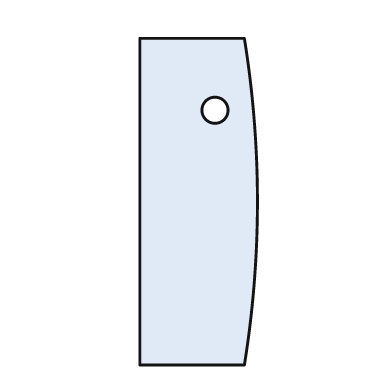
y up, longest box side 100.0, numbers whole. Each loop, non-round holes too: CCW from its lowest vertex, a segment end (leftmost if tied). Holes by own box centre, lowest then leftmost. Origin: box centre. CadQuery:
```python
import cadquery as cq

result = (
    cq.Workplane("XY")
    .moveTo(-18.0, -50.0)
    .lineTo(14.0, -50.0)
    .threePointArc((18.0, 0.0), (14.0, 50.0))
    .lineTo(-18.0, 50.0)
    .close()
    .moveTo(5.0, 28.0)
    .circle(4.0)
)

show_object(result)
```